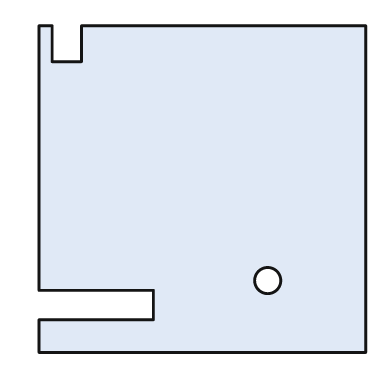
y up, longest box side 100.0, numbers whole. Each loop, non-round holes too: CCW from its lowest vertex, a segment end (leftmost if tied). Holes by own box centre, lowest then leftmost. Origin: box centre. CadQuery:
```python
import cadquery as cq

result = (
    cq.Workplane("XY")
    .moveTo(-50.0, -50.0)
    .lineTo(50.0, -50.0)
    .lineTo(50.0, 50.0)
    .lineTo(-37.0, 50.0)
    .lineTo(-37.0, 39.0)
    .lineTo(-46.0, 39.0)
    .lineTo(-46.0, 50.0)
    .lineTo(-50.0, 50.0)
    .lineTo(-50.0, -31.0)
    .lineTo(-15.0, -31.0)
    .lineTo(-15.0, -40.0)
    .lineTo(-50.0, -40.0)
    .close()
    .moveTo(20.0, -28.0)
    .circle(4.0)
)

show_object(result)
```